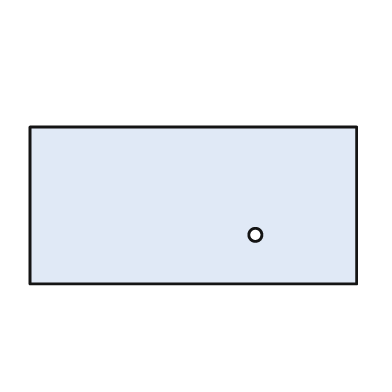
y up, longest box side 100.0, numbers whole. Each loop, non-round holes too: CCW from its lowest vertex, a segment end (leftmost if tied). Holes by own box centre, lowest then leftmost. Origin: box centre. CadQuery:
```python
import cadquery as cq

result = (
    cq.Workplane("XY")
    .moveTo(-50.0, -24.0)
    .lineTo(50.0, -24.0)
    .lineTo(50.0, 24.0)
    .lineTo(-50.0, 24.0)
    .close()
    .moveTo(19.0, -9.0)
    .circle(2.0)
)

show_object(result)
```